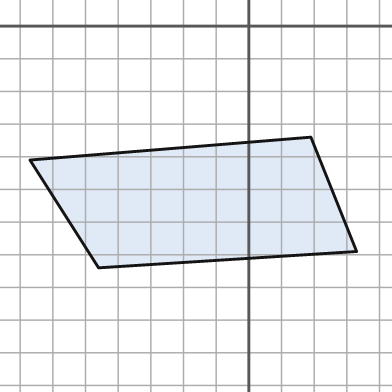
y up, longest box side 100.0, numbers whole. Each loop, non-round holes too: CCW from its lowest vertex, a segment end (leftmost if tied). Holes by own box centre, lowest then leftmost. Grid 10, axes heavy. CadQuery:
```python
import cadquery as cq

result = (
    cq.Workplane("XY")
    .moveTo(-46.0, -74.0)
    .lineTo(33.0, -69.0)
    .lineTo(19.0, -34.0)
    .lineTo(-67.0, -41.0)
    .close()
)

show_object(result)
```